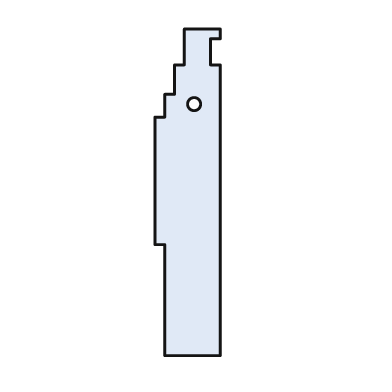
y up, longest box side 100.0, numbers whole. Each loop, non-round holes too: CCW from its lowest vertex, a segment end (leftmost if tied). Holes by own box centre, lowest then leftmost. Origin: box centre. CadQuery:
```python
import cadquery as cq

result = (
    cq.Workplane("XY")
    .moveTo(-7.0, -50.0)
    .lineTo(10.0, -50.0)
    .lineTo(10.0, 39.0)
    .lineTo(7.0, 39.0)
    .lineTo(7.0, 47.0)
    .lineTo(10.0, 47.0)
    .lineTo(10.0, 50.0)
    .lineTo(-1.0, 50.0)
    .lineTo(-1.0, 39.0)
    .lineTo(-4.0, 39.0)
    .lineTo(-4.0, 30.0)
    .lineTo(-7.0, 30.0)
    .lineTo(-7.0, 23.0)
    .lineTo(-10.0, 23.0)
    .lineTo(-10.0, -16.0)
    .lineTo(-7.0, -16.0)
    .close()
    .moveTo(2.0, 27.0)
    .circle(2.0)
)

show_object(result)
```